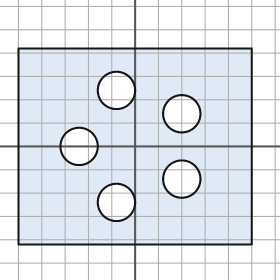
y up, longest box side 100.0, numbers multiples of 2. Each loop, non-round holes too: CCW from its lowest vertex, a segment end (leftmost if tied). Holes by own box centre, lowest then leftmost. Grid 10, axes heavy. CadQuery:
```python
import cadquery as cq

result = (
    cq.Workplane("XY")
    .moveTo(-50.0, -42.0)
    .lineTo(50.0, -42.0)
    .lineTo(50.0, 42.0)
    .lineTo(-50.0, 42.0)
    .close()
    .moveTo(-8.0, -24.0)
    .circle(8.0)
    .moveTo(20.0, -14.0)
    .circle(8.0)
    .moveTo(-24.0, 0.0)
    .circle(8.0)
    .moveTo(20.0, 14.0)
    .circle(8.0)
    .moveTo(-8.0, 24.0)
    .circle(8.0)
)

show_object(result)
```